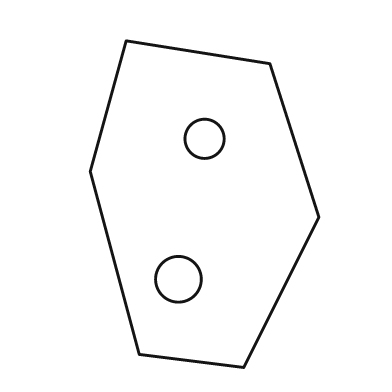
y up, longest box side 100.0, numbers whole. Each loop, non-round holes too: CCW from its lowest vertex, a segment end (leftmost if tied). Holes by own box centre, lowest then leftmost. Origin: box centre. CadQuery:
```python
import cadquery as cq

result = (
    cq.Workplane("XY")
    .moveTo(12.0, -50.0)
    .lineTo(35.0, -4.0)
    .lineTo(20.0, 43.0)
    .lineTo(-24.0, 50.0)
    .lineTo(-35.0, 10.0)
    .lineTo(-20.0, -46.0)
    .close()
    .moveTo(-8.0, -23.0)
    .circle(7.0)
    .moveTo(0.0, 20.0)
    .circle(6.0)
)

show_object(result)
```